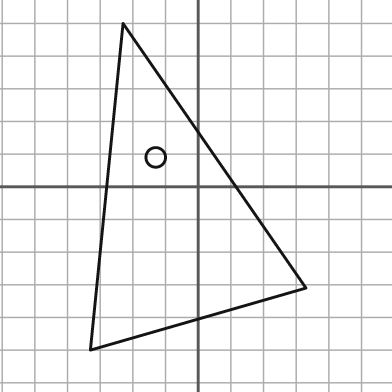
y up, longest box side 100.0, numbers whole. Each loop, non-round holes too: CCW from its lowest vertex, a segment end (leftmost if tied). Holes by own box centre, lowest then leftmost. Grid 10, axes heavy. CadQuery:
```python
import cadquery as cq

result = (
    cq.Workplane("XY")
    .moveTo(-33.0, -50.0)
    .lineTo(33.0, -31.0)
    .lineTo(-23.0, 50.0)
    .close()
    .moveTo(-13.0, 9.0)
    .circle(3.0)
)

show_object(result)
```